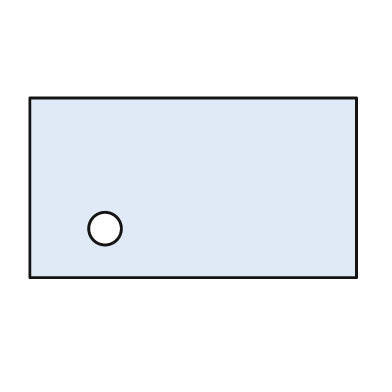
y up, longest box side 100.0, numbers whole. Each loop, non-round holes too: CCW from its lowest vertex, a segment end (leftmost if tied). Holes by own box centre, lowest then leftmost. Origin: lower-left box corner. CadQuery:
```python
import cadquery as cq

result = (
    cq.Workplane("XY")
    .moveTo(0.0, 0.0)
    .lineTo(100.0, 0.0)
    .lineTo(100.0, 55.0)
    .lineTo(0.0, 55.0)
    .close()
    .moveTo(23.0, 15.0)
    .circle(5.0)
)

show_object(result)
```